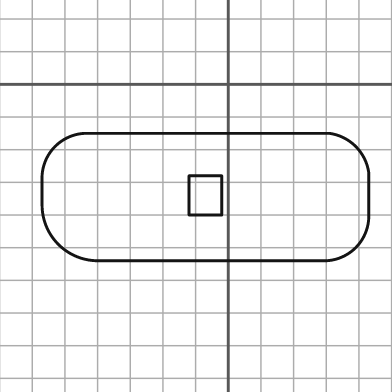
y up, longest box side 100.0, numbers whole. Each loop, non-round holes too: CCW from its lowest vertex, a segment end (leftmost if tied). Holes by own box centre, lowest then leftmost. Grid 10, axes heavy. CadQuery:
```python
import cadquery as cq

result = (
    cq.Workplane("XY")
    .moveTo(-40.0, -54.0)
    .lineTo(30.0, -54.0)
    .threePointArc((39.0, -50.0), (43.0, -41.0))
    .lineTo(43.0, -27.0)
    .threePointArc((39.0, -19.0), (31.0, -15.0))
    .lineTo(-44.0, -15.0)
    .threePointArc((-53.0, -19.0), (-57.0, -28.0))
    .lineTo(-57.0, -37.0)
    .threePointArc((-52.0, -49.0), (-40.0, -54.0))
    .close()
    .moveTo(-12.0, -40.0)
    .lineTo(-2.0, -40.0)
    .lineTo(-2.0, -28.0)
    .lineTo(-12.0, -28.0)
    .close()
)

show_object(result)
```